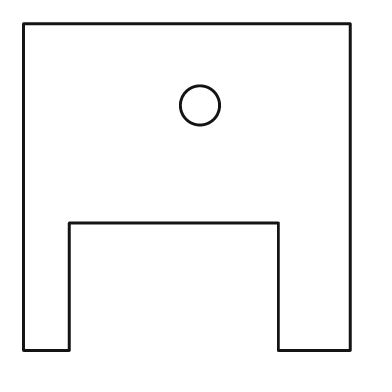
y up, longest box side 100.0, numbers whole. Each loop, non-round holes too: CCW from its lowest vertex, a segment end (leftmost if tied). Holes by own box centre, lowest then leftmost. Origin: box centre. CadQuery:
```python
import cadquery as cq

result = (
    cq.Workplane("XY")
    .moveTo(-50.0, -50.0)
    .lineTo(-36.0, -50.0)
    .lineTo(-36.0, -11.0)
    .lineTo(28.0, -11.0)
    .lineTo(28.0, -50.0)
    .lineTo(50.0, -50.0)
    .lineTo(50.0, 50.0)
    .lineTo(-50.0, 50.0)
    .close()
    .moveTo(4.0, 25.0)
    .circle(6.0)
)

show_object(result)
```